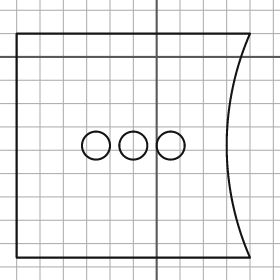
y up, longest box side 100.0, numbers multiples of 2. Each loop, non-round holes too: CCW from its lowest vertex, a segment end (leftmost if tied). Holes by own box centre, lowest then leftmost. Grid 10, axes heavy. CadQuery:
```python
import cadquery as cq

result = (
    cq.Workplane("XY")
    .moveTo(-60.0, -86.0)
    .lineTo(40.0, -86.0)
    .threePointArc((30.0, -38.0), (40.0, 10.0))
    .lineTo(-60.0, 10.0)
    .close()
    .moveTo(-26.0, -38.0)
    .circle(6.0)
    .moveTo(-10.0, -38.0)
    .circle(6.0)
    .moveTo(6.0, -38.0)
    .circle(6.0)
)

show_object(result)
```